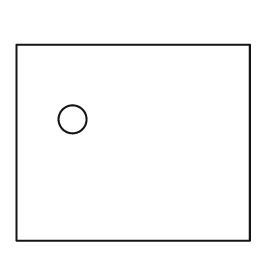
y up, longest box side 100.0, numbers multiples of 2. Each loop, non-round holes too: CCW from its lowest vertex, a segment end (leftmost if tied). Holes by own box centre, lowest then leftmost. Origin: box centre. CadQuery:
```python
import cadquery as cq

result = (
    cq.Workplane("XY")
    .moveTo(-50.0, -42.0)
    .lineTo(50.0, -42.0)
    .lineTo(50.0, 42.0)
    .lineTo(-50.0, 42.0)
    .close()
    .moveTo(-26.0, 10.0)
    .circle(6.0)
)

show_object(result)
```